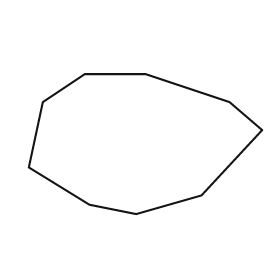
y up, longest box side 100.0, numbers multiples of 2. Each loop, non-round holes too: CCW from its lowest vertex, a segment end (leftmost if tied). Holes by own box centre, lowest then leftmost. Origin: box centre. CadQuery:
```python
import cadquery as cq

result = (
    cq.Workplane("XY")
    .moveTo(-4.0, -30.0)
    .lineTo(24.0, -22.0)
    .lineTo(50.0, 6.0)
    .lineTo(36.0, 18.0)
    .lineTo(0.0, 30.0)
    .lineTo(-26.0, 30.0)
    .lineTo(-44.0, 18.0)
    .lineTo(-50.0, -10.0)
    .lineTo(-24.0, -26.0)
    .close()
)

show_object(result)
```